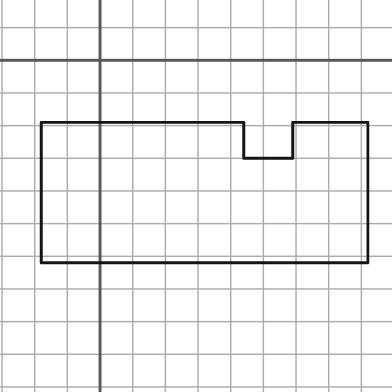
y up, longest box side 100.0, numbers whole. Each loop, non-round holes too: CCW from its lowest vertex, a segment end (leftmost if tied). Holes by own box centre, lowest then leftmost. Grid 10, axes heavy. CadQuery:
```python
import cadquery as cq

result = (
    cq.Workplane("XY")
    .moveTo(-18.0, -62.0)
    .lineTo(82.0, -62.0)
    .lineTo(82.0, -19.0)
    .lineTo(59.0, -19.0)
    .lineTo(59.0, -30.0)
    .lineTo(44.0, -30.0)
    .lineTo(44.0, -19.0)
    .lineTo(-18.0, -19.0)
    .close()
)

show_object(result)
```